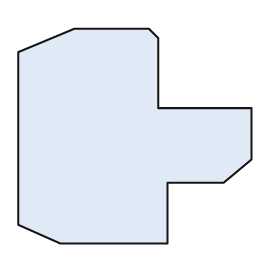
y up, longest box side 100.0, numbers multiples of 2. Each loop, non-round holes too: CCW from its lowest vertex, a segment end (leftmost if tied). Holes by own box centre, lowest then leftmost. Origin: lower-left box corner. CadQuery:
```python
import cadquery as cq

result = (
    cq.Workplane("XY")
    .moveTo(18.0, 0.0)
    .lineTo(64.0, 0.0)
    .lineTo(64.0, 26.0)
    .lineTo(88.0, 26.0)
    .lineTo(100.0, 36.0)
    .lineTo(100.0, 58.0)
    .lineTo(60.0, 58.0)
    .lineTo(60.0, 88.0)
    .lineTo(56.0, 92.0)
    .lineTo(24.0, 92.0)
    .lineTo(0.0, 82.0)
    .lineTo(0.0, 8.0)
    .close()
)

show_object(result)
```